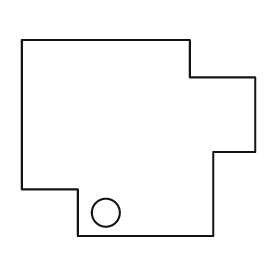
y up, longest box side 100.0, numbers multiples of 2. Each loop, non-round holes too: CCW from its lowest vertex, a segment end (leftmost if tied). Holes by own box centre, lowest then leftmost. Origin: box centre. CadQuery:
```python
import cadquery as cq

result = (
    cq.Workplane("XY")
    .moveTo(-26.0, -42.0)
    .lineTo(32.0, -42.0)
    .lineTo(32.0, -6.0)
    .lineTo(50.0, -6.0)
    .lineTo(50.0, 26.0)
    .lineTo(22.0, 26.0)
    .lineTo(22.0, 42.0)
    .lineTo(-50.0, 42.0)
    .lineTo(-50.0, -22.0)
    .lineTo(-26.0, -22.0)
    .close()
    .moveTo(-14.0, -32.0)
    .circle(6.0)
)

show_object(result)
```